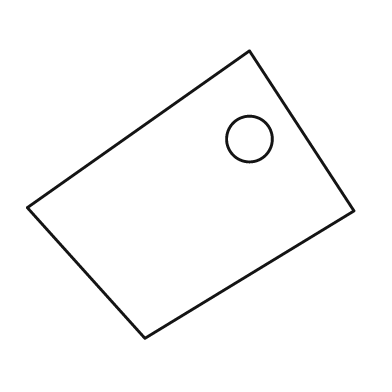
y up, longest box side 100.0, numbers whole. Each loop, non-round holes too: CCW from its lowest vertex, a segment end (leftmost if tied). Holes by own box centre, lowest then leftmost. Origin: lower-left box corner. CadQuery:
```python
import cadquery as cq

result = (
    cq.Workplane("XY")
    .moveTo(36.0, 0.0)
    .lineTo(100.0, 39.0)
    .lineTo(68.0, 88.0)
    .lineTo(0.0, 40.0)
    .close()
    .moveTo(68.0, 61.0)
    .circle(7.0)
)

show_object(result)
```